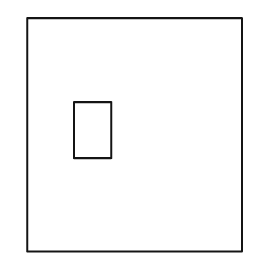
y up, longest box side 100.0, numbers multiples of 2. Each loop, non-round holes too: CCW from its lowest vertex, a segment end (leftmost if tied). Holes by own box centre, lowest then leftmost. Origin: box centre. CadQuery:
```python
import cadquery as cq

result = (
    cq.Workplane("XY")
    .moveTo(-46.0, -50.0)
    .lineTo(46.0, -50.0)
    .lineTo(46.0, 50.0)
    .lineTo(-46.0, 50.0)
    .close()
    .moveTo(-26.0, -10.0)
    .lineTo(-10.0, -10.0)
    .lineTo(-10.0, 14.0)
    .lineTo(-26.0, 14.0)
    .close()
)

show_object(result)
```